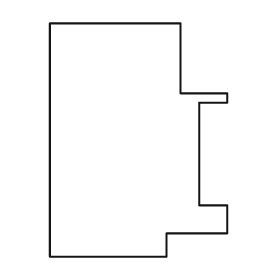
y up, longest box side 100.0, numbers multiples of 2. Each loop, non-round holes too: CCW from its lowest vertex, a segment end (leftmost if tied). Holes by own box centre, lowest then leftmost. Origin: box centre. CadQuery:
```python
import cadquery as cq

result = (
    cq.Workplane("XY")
    .moveTo(-38.0, -50.0)
    .lineTo(12.0, -50.0)
    .lineTo(12.0, -40.0)
    .lineTo(38.0, -40.0)
    .lineTo(38.0, -28.0)
    .lineTo(26.0, -28.0)
    .lineTo(26.0, 16.0)
    .lineTo(38.0, 16.0)
    .lineTo(38.0, 20.0)
    .lineTo(18.0, 20.0)
    .lineTo(18.0, 50.0)
    .lineTo(-38.0, 50.0)
    .close()
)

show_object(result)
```